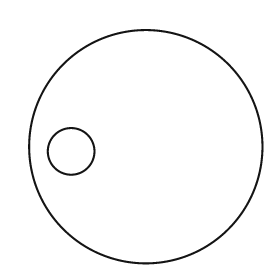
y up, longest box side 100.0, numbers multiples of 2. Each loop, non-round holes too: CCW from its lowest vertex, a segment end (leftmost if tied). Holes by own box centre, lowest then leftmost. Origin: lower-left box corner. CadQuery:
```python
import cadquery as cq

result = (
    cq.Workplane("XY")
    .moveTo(50.0, 50.0)
    .circle(50.0)
    .moveTo(18.0, 48.0)
    .circle(10.0)
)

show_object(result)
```